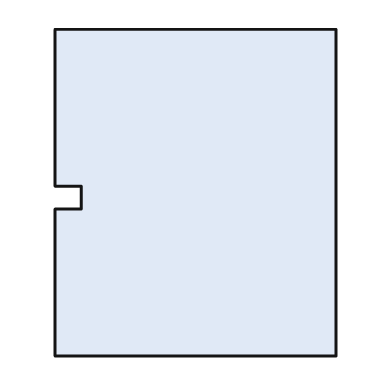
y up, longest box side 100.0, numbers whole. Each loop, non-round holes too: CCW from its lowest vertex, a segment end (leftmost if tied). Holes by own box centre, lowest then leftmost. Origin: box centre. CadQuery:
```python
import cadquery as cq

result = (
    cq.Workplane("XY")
    .moveTo(-43.0, -50.0)
    .lineTo(43.0, -50.0)
    .lineTo(43.0, 50.0)
    .lineTo(-43.0, 50.0)
    .lineTo(-43.0, 2.0)
    .lineTo(-35.0, 2.0)
    .lineTo(-35.0, -5.0)
    .lineTo(-43.0, -5.0)
    .close()
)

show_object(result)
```